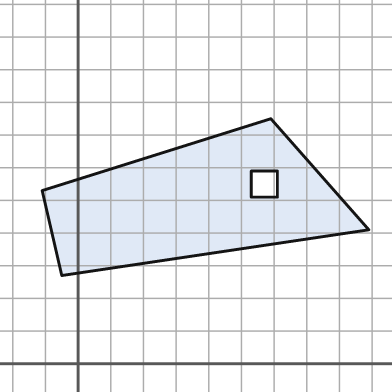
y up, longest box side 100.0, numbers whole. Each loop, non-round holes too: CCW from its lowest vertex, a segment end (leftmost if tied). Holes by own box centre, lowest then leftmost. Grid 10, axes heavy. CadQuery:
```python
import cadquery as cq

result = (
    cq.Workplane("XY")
    .moveTo(-5.0, 27.0)
    .lineTo(89.0, 41.0)
    .lineTo(59.0, 75.0)
    .lineTo(-11.0, 53.0)
    .close()
    .moveTo(53.0, 51.0)
    .lineTo(61.0, 51.0)
    .lineTo(61.0, 59.0)
    .lineTo(53.0, 59.0)
    .close()
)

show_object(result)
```